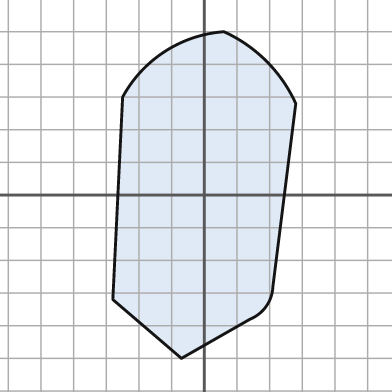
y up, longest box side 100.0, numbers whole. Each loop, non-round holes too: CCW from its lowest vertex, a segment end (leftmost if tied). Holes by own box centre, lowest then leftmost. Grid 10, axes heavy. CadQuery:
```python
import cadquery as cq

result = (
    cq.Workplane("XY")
    .moveTo(-7.0, -50.0)
    .lineTo(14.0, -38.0)
    .threePointArc((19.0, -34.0), (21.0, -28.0))
    .lineTo(28.0, 28.0)
    .threePointArc((19.0, 41.0), (6.0, 50.0))
    .threePointArc((-12.0, 44.0), (-25.0, 30.0))
    .lineTo(-28.0, -32.0)
    .close()
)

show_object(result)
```